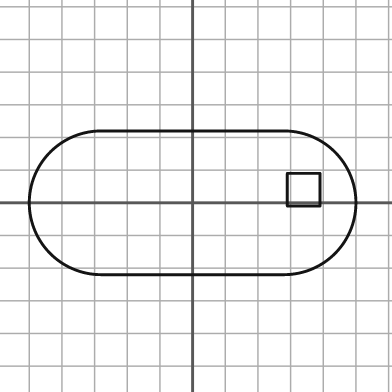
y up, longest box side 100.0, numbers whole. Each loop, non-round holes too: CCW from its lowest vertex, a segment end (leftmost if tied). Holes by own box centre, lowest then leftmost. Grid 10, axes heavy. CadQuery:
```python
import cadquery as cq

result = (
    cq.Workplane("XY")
    .moveTo(-28.0, -22.0)
    .lineTo(28.0, -22.0)
    .threePointArc((50.0, 0.0), (28.0, 22.0))
    .lineTo(-28.0, 22.0)
    .threePointArc((-50.0, 0.0), (-28.0, -22.0))
    .close()
    .moveTo(29.0, -1.0)
    .lineTo(39.0, -1.0)
    .lineTo(39.0, 9.0)
    .lineTo(29.0, 9.0)
    .close()
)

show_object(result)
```